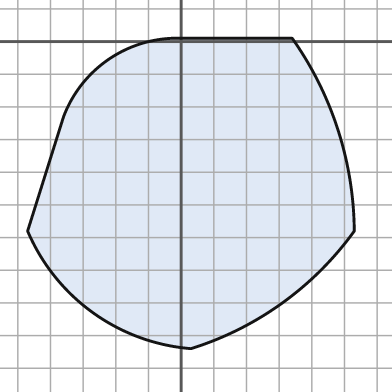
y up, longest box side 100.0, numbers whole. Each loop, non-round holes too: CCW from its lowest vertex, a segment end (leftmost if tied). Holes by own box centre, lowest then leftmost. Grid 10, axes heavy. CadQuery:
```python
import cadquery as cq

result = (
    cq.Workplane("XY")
    .moveTo(3.0, -94.0)
    .threePointArc((31.0, -80.0), (53.0, -58.0))
    .threePointArc((48.0, -27.0), (34.0, 1.0))
    .lineTo(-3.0, 1.0)
    .threePointArc((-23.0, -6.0), (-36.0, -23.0))
    .lineTo(-47.0, -58.0)
    .threePointArc((-27.0, -83.0), (3.0, -94.0))
    .close()
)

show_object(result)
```